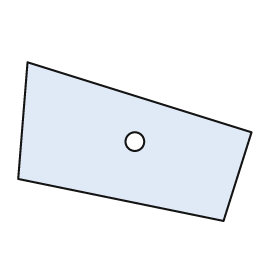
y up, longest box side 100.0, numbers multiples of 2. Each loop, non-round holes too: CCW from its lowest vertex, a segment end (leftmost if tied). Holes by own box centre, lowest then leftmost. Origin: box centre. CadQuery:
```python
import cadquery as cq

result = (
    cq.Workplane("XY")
    .moveTo(38.0, -34.0)
    .lineTo(50.0, 4.0)
    .lineTo(-46.0, 34.0)
    .lineTo(-50.0, -16.0)
    .close()
    .moveTo(0.0, 0.0)
    .circle(4.0)
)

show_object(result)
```